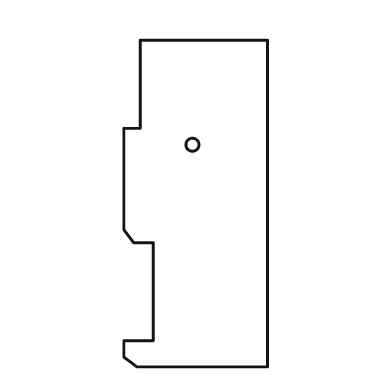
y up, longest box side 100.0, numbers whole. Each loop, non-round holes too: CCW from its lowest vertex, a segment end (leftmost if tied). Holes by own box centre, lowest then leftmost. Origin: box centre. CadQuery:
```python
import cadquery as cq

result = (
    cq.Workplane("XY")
    .moveTo(-18.0, -50.0)
    .lineTo(22.0, -50.0)
    .lineTo(22.0, 50.0)
    .lineTo(-17.0, 50.0)
    .lineTo(-17.0, 23.0)
    .lineTo(-22.0, 23.0)
    .lineTo(-22.0, -8.0)
    .lineTo(-19.0, -12.0)
    .lineTo(-13.0, -12.0)
    .lineTo(-13.0, -42.0)
    .lineTo(-22.0, -42.0)
    .lineTo(-22.0, -47.0)
    .close()
    .moveTo(-1.0, 18.0)
    .circle(2.0)
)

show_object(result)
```